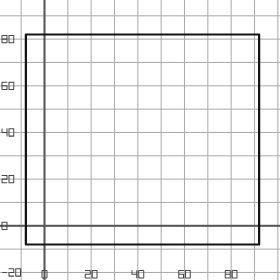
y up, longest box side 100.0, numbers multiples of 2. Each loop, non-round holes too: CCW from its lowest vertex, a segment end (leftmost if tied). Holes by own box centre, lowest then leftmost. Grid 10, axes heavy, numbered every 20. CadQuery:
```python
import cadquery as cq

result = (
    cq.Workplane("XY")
    .moveTo(-8.0, -8.0)
    .lineTo(92.0, -8.0)
    .lineTo(92.0, 82.0)
    .lineTo(-8.0, 82.0)
    .close()
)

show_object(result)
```